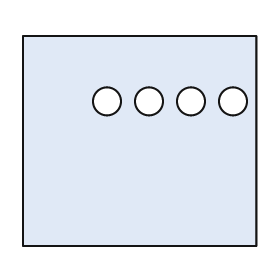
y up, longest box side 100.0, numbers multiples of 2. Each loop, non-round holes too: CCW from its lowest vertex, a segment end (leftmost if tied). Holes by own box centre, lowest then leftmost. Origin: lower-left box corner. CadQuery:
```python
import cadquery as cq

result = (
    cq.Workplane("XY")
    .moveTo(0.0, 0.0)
    .lineTo(100.0, 0.0)
    .lineTo(100.0, 90.0)
    .lineTo(0.0, 90.0)
    .close()
    .moveTo(36.0, 62.0)
    .circle(6.0)
    .moveTo(54.0, 62.0)
    .circle(6.0)
    .moveTo(72.0, 62.0)
    .circle(6.0)
    .moveTo(90.0, 62.0)
    .circle(6.0)
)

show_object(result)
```